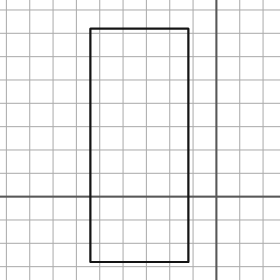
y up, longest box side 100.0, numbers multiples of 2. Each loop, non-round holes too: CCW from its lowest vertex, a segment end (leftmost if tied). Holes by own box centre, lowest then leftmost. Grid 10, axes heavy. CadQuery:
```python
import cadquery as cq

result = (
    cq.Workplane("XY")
    .moveTo(-54.0, -28.0)
    .lineTo(-12.0, -28.0)
    .lineTo(-12.0, 72.0)
    .lineTo(-54.0, 72.0)
    .close()
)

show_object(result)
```